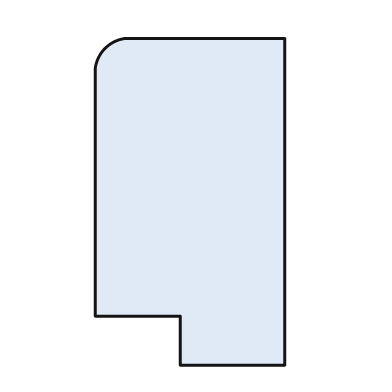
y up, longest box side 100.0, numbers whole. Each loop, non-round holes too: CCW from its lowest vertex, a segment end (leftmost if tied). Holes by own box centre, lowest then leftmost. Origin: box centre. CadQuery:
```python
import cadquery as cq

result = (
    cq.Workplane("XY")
    .moveTo(-3.0, -50.0)
    .lineTo(29.0, -50.0)
    .lineTo(29.0, 50.0)
    .lineTo(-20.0, 50.0)
    .threePointArc((-26.0, 47.0), (-29.0, 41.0))
    .lineTo(-29.0, -35.0)
    .lineTo(-3.0, -35.0)
    .close()
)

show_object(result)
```